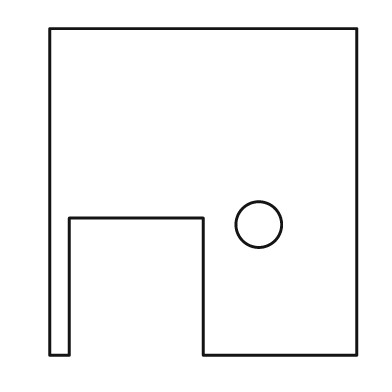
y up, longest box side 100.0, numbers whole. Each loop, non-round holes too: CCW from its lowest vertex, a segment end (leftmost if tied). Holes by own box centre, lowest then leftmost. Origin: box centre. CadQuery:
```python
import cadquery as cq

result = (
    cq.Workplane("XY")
    .moveTo(-47.0, -50.0)
    .lineTo(-41.0, -50.0)
    .lineTo(-41.0, -8.0)
    .lineTo(0.0, -8.0)
    .lineTo(0.0, -50.0)
    .lineTo(47.0, -50.0)
    .lineTo(47.0, 50.0)
    .lineTo(-47.0, 50.0)
    .close()
    .moveTo(17.0, -10.0)
    .circle(7.0)
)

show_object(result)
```